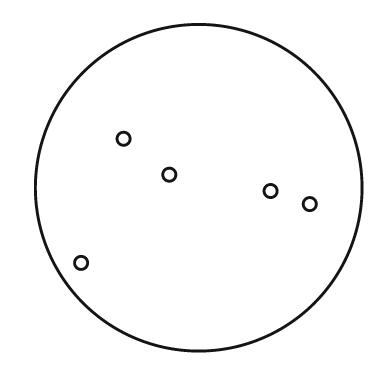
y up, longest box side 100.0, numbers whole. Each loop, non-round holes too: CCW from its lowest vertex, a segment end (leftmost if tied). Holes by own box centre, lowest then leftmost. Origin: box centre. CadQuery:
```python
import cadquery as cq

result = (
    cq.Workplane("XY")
    .moveTo(0.0, 0.0)
    .circle(50.0)
    .moveTo(-36.0, -23.0)
    .circle(2.0)
    .moveTo(34.0, -5.0)
    .circle(2.0)
    .moveTo(22.0, -1.0)
    .circle(2.0)
    .moveTo(-9.0, 4.0)
    .circle(2.0)
    .moveTo(-23.0, 15.0)
    .circle(2.0)
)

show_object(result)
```